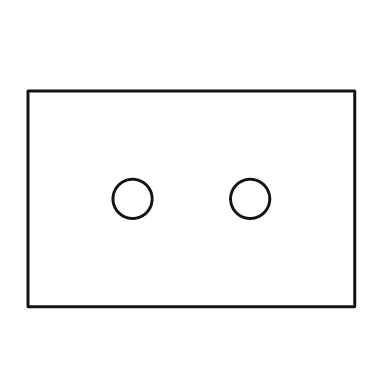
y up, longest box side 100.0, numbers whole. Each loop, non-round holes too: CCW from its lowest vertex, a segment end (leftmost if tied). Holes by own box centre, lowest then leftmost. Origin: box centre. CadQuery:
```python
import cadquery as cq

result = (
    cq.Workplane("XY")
    .moveTo(-50.0, -33.0)
    .lineTo(50.0, -33.0)
    .lineTo(50.0, 33.0)
    .lineTo(-50.0, 33.0)
    .close()
    .moveTo(-18.0, 0.0)
    .circle(6.0)
    .moveTo(18.0, 0.0)
    .circle(6.0)
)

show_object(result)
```